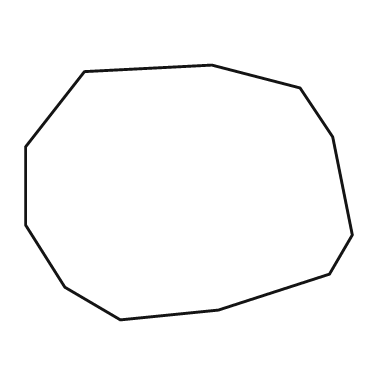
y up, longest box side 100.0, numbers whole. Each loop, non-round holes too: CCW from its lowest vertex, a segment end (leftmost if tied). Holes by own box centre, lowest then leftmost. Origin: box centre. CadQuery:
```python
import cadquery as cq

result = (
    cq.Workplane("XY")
    .moveTo(-21.0, -39.0)
    .lineTo(9.0, -36.0)
    .lineTo(43.0, -25.0)
    .lineTo(50.0, -13.0)
    .lineTo(44.0, 17.0)
    .lineTo(34.0, 32.0)
    .lineTo(7.0, 39.0)
    .lineTo(-32.0, 37.0)
    .lineTo(-50.0, 14.0)
    .lineTo(-50.0, -10.0)
    .lineTo(-38.0, -29.0)
    .close()
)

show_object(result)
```